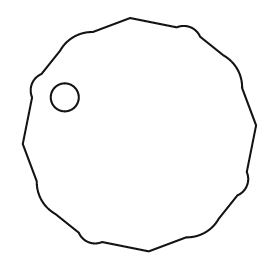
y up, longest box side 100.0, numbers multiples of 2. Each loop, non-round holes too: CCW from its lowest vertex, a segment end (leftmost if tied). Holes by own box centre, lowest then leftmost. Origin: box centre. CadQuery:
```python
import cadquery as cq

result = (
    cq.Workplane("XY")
    .moveTo(4.0, -50.0)
    .lineTo(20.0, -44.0)
    .threePointArc((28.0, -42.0), (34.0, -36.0))
    .lineTo(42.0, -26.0)
    .threePointArc((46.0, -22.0), (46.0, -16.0))
    .lineTo(50.0, 4.0)
    .lineTo(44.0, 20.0)
    .threePointArc((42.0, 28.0), (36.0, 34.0))
    .lineTo(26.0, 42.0)
    .threePointArc((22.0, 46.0), (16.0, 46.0))
    .lineTo(-4.0, 50.0)
    .lineTo(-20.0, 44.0)
    .threePointArc((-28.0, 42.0), (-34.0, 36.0))
    .lineTo(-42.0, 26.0)
    .threePointArc((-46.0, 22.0), (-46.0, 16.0))
    .lineTo(-50.0, -4.0)
    .lineTo(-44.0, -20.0)
    .threePointArc((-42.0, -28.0), (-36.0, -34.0))
    .lineTo(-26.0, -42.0)
    .threePointArc((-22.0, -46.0), (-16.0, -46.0))
    .close()
    .moveTo(-32.0, 16.0)
    .circle(6.0)
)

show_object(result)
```